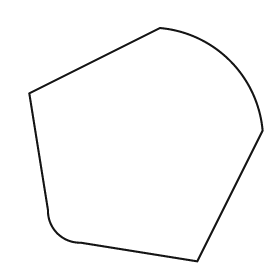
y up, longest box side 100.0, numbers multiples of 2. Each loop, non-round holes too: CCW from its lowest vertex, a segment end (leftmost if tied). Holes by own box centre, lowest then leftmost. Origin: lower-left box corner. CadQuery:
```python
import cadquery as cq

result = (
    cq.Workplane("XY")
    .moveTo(72.0, 0.0)
    .lineTo(100.0, 56.0)
    .threePointArc((86.0, 86.0), (56.0, 100.0))
    .lineTo(0.0, 72.0)
    .lineTo(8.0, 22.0)
    .threePointArc((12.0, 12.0), (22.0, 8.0))
    .close()
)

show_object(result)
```